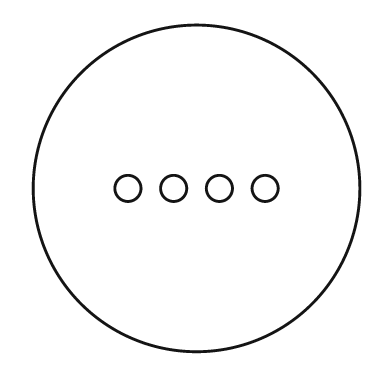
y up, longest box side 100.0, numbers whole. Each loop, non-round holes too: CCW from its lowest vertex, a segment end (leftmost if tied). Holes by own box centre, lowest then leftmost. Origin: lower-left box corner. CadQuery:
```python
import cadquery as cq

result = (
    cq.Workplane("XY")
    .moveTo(50.0, 50.0)
    .circle(50.0)
    .moveTo(29.0, 50.0)
    .circle(4.0)
    .moveTo(43.0, 50.0)
    .circle(4.0)
    .moveTo(57.0, 50.0)
    .circle(4.0)
    .moveTo(71.0, 50.0)
    .circle(4.0)
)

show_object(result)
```